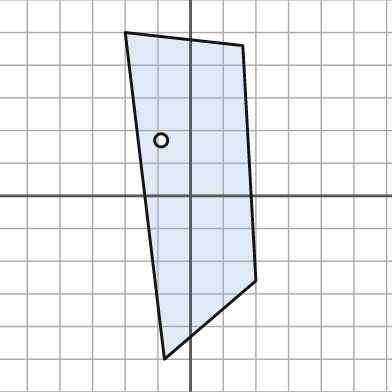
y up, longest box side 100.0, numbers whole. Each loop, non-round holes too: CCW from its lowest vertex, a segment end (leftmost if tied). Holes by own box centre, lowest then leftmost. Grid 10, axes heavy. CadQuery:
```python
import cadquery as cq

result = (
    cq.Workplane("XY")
    .moveTo(-8.0, -50.0)
    .lineTo(20.0, -26.0)
    .lineTo(16.0, 46.0)
    .lineTo(-20.0, 50.0)
    .close()
    .moveTo(-9.0, 17.0)
    .circle(2.0)
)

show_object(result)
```